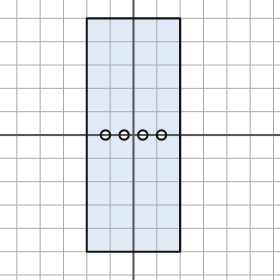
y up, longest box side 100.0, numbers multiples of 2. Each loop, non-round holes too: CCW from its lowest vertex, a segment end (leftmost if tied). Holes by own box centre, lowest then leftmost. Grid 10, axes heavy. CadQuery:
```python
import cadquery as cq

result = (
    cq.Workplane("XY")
    .moveTo(-20.0, -50.0)
    .lineTo(20.0, -50.0)
    .lineTo(20.0, 50.0)
    .lineTo(-20.0, 50.0)
    .close()
    .moveTo(-12.0, 0.0)
    .circle(2.0)
    .moveTo(-4.0, 0.0)
    .circle(2.0)
    .moveTo(4.0, 0.0)
    .circle(2.0)
    .moveTo(12.0, 0.0)
    .circle(2.0)
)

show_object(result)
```